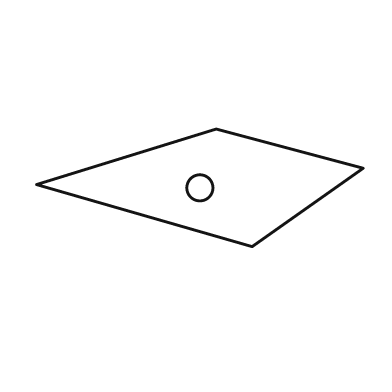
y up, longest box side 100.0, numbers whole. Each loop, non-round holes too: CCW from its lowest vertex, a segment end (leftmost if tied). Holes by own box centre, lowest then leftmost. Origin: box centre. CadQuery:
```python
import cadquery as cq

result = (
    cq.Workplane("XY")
    .moveTo(16.0, -18.0)
    .lineTo(50.0, 6.0)
    .lineTo(5.0, 18.0)
    .lineTo(-50.0, 1.0)
    .close()
    .moveTo(0.0, 0.0)
    .circle(4.0)
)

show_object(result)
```